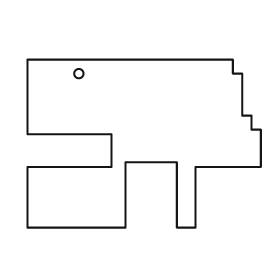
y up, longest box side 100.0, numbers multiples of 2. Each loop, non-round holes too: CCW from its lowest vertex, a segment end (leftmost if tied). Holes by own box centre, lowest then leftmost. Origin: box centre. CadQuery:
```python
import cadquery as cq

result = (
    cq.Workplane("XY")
    .moveTo(-50.0, -36.0)
    .lineTo(-8.0, -36.0)
    .lineTo(-8.0, -8.0)
    .lineTo(14.0, -8.0)
    .lineTo(14.0, -36.0)
    .lineTo(22.0, -36.0)
    .lineTo(22.0, -10.0)
    .lineTo(50.0, -10.0)
    .lineTo(50.0, 6.0)
    .lineTo(46.0, 6.0)
    .lineTo(46.0, 12.0)
    .lineTo(42.0, 12.0)
    .lineTo(42.0, 30.0)
    .lineTo(38.0, 30.0)
    .lineTo(38.0, 36.0)
    .lineTo(-50.0, 36.0)
    .lineTo(-50.0, 4.0)
    .lineTo(-14.0, 4.0)
    .lineTo(-14.0, -10.0)
    .lineTo(-50.0, -10.0)
    .close()
    .moveTo(-28.0, 30.0)
    .circle(2.0)
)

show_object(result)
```